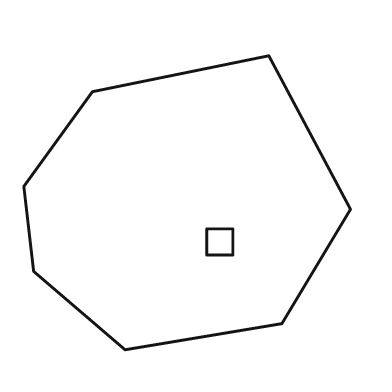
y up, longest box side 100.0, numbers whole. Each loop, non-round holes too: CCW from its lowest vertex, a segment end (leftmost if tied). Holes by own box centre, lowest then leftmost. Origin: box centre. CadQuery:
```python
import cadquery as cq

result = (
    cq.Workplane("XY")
    .moveTo(-19.0, -45.0)
    .lineTo(29.0, -37.0)
    .lineTo(50.0, -2.0)
    .lineTo(25.0, 45.0)
    .lineTo(-29.0, 34.0)
    .lineTo(-50.0, 5.0)
    .lineTo(-47.0, -21.0)
    .close()
    .moveTo(6.0, -16.0)
    .lineTo(14.0, -16.0)
    .lineTo(14.0, -8.0)
    .lineTo(6.0, -8.0)
    .close()
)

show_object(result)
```